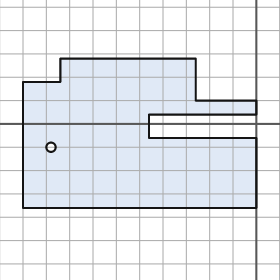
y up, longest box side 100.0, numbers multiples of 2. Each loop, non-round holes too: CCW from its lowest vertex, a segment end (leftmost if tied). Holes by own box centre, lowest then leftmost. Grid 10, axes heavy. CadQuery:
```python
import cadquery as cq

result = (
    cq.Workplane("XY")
    .moveTo(-100.0, -36.0)
    .lineTo(0.0, -36.0)
    .lineTo(0.0, -6.0)
    .lineTo(-46.0, -6.0)
    .lineTo(-46.0, 4.0)
    .lineTo(0.0, 4.0)
    .lineTo(0.0, 10.0)
    .lineTo(-26.0, 10.0)
    .lineTo(-26.0, 28.0)
    .lineTo(-84.0, 28.0)
    .lineTo(-84.0, 18.0)
    .lineTo(-100.0, 18.0)
    .close()
    .moveTo(-88.0, -10.0)
    .circle(2.0)
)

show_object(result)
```